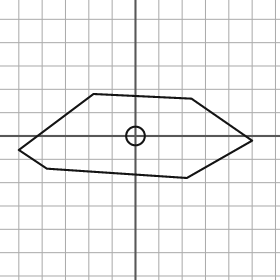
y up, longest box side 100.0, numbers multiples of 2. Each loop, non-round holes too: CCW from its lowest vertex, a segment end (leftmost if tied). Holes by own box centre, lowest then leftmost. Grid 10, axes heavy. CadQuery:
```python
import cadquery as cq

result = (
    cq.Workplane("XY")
    .moveTo(22.0, -18.0)
    .lineTo(50.0, -2.0)
    .lineTo(24.0, 16.0)
    .lineTo(-18.0, 18.0)
    .lineTo(-50.0, -6.0)
    .lineTo(-38.0, -14.0)
    .close()
    .moveTo(0.0, 0.0)
    .circle(4.0)
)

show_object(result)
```